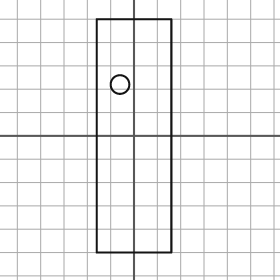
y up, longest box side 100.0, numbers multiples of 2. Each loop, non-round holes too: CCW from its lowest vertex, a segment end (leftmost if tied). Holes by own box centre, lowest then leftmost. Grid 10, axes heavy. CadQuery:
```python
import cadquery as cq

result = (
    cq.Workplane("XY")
    .moveTo(-16.0, -50.0)
    .lineTo(16.0, -50.0)
    .lineTo(16.0, 50.0)
    .lineTo(-16.0, 50.0)
    .close()
    .moveTo(-6.0, 22.0)
    .circle(4.0)
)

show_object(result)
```